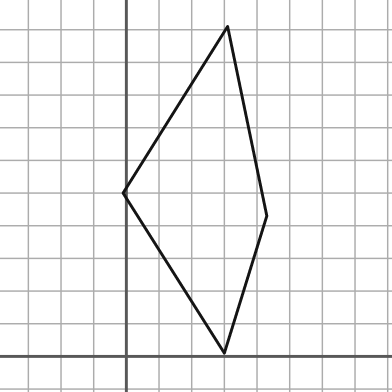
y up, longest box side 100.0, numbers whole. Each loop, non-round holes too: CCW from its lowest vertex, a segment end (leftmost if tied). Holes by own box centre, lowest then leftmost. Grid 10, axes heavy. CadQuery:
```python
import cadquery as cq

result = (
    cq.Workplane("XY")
    .moveTo(30.0, 1.0)
    .lineTo(43.0, 43.0)
    .lineTo(31.0, 101.0)
    .lineTo(-1.0, 50.0)
    .close()
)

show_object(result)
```